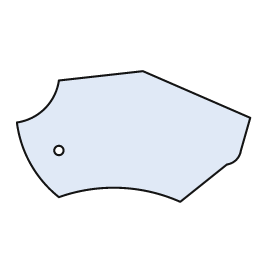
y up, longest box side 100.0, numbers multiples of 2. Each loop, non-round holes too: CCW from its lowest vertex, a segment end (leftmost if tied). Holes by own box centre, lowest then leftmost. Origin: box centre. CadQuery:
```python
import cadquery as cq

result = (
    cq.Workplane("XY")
    .moveTo(20.0, -28.0)
    .lineTo(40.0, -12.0)
    .threePointArc((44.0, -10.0), (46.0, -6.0))
    .lineTo(50.0, 8.0)
    .lineTo(4.0, 28.0)
    .lineTo(-32.0, 24.0)
    .threePointArc((-38.0, 12.0), (-50.0, 6.0))
    .threePointArc((-44.0, -12.0), (-32.0, -26.0))
    .threePointArc((-6.0, -22.0), (20.0, -28.0))
    .close()
    .moveTo(-32.0, -6.0)
    .circle(2.0)
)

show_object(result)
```